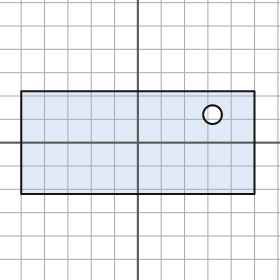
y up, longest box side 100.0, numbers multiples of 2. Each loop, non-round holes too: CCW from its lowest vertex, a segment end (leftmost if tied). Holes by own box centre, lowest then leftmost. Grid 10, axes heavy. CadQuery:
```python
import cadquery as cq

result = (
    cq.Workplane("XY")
    .moveTo(-50.0, -22.0)
    .lineTo(50.0, -22.0)
    .lineTo(50.0, 22.0)
    .lineTo(-50.0, 22.0)
    .close()
    .moveTo(32.0, 12.0)
    .circle(4.0)
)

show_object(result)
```